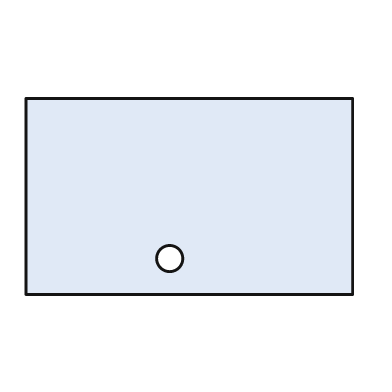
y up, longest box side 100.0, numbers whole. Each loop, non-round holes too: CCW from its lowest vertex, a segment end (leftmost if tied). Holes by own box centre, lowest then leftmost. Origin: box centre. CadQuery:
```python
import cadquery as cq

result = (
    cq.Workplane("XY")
    .moveTo(-50.0, -30.0)
    .lineTo(50.0, -30.0)
    .lineTo(50.0, 30.0)
    .lineTo(-50.0, 30.0)
    .close()
    .moveTo(-6.0, -19.0)
    .circle(4.0)
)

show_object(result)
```